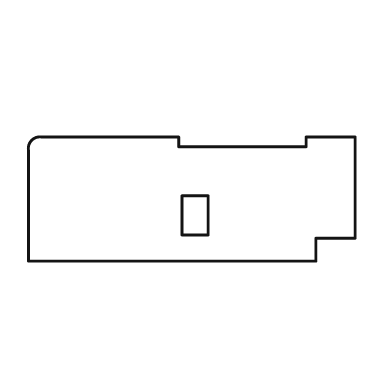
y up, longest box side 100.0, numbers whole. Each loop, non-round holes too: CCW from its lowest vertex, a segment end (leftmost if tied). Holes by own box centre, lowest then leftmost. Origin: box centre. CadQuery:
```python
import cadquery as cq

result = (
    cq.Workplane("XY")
    .moveTo(-50.0, -19.0)
    .lineTo(38.0, -19.0)
    .lineTo(38.0, -12.0)
    .lineTo(50.0, -12.0)
    .lineTo(50.0, 19.0)
    .lineTo(35.0, 19.0)
    .lineTo(35.0, 16.0)
    .lineTo(-4.0, 16.0)
    .lineTo(-4.0, 19.0)
    .lineTo(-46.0, 19.0)
    .threePointArc((-49.0, 18.0), (-50.0, 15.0))
    .close()
    .moveTo(-3.0, -11.0)
    .lineTo(5.0, -11.0)
    .lineTo(5.0, 1.0)
    .lineTo(-3.0, 1.0)
    .close()
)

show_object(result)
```